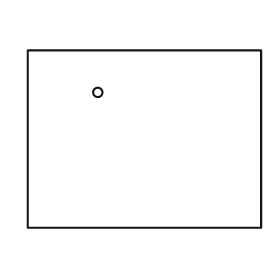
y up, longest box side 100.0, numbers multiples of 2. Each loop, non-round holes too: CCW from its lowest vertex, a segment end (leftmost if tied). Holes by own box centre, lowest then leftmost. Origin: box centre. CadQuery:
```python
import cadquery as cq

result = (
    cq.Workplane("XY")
    .moveTo(-50.0, -38.0)
    .lineTo(50.0, -38.0)
    .lineTo(50.0, 38.0)
    .lineTo(-50.0, 38.0)
    .close()
    .moveTo(-20.0, 20.0)
    .circle(2.0)
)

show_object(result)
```